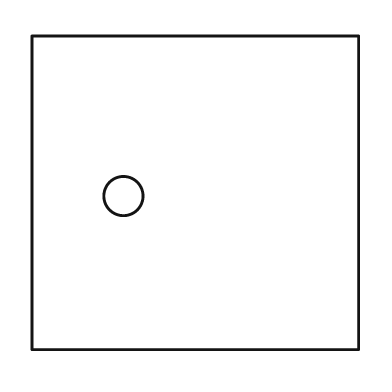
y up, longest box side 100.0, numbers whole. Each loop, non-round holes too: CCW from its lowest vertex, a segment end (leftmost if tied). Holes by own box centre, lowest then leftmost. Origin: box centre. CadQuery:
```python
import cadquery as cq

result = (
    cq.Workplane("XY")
    .moveTo(-50.0, -48.0)
    .lineTo(50.0, -48.0)
    .lineTo(50.0, 48.0)
    .lineTo(-50.0, 48.0)
    .close()
    .moveTo(-22.0, -1.0)
    .circle(6.0)
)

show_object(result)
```